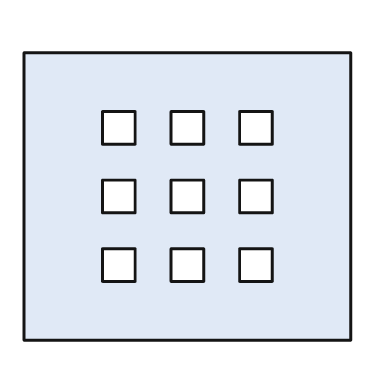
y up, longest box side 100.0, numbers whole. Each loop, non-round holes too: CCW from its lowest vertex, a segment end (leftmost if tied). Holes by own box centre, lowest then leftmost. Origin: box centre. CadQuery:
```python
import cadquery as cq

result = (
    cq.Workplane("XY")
    .moveTo(-50.0, -44.0)
    .lineTo(50.0, -44.0)
    .lineTo(50.0, 44.0)
    .lineTo(-50.0, 44.0)
    .close()
    .moveTo(-26.0, -26.0)
    .lineTo(-16.0, -26.0)
    .lineTo(-16.0, -16.0)
    .lineTo(-26.0, -16.0)
    .close()
    .moveTo(-5.0, -26.0)
    .lineTo(5.0, -26.0)
    .lineTo(5.0, -16.0)
    .lineTo(-5.0, -16.0)
    .close()
    .moveTo(16.0, -26.0)
    .lineTo(26.0, -26.0)
    .lineTo(26.0, -16.0)
    .lineTo(16.0, -16.0)
    .close()
    .moveTo(-26.0, -5.0)
    .lineTo(-16.0, -5.0)
    .lineTo(-16.0, 5.0)
    .lineTo(-26.0, 5.0)
    .close()
    .moveTo(-5.0, -5.0)
    .lineTo(5.0, -5.0)
    .lineTo(5.0, 5.0)
    .lineTo(-5.0, 5.0)
    .close()
    .moveTo(16.0, -5.0)
    .lineTo(26.0, -5.0)
    .lineTo(26.0, 5.0)
    .lineTo(16.0, 5.0)
    .close()
    .moveTo(-26.0, 16.0)
    .lineTo(-16.0, 16.0)
    .lineTo(-16.0, 26.0)
    .lineTo(-26.0, 26.0)
    .close()
    .moveTo(-5.0, 16.0)
    .lineTo(5.0, 16.0)
    .lineTo(5.0, 26.0)
    .lineTo(-5.0, 26.0)
    .close()
    .moveTo(16.0, 16.0)
    .lineTo(26.0, 16.0)
    .lineTo(26.0, 26.0)
    .lineTo(16.0, 26.0)
    .close()
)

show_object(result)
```